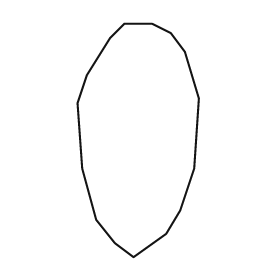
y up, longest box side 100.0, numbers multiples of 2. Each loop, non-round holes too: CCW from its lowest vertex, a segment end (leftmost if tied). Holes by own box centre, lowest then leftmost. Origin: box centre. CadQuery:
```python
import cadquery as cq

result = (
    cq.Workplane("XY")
    .moveTo(-2.0, -50.0)
    .lineTo(12.0, -40.0)
    .lineTo(18.0, -30.0)
    .lineTo(24.0, -12.0)
    .lineTo(26.0, 18.0)
    .lineTo(20.0, 38.0)
    .lineTo(14.0, 46.0)
    .lineTo(6.0, 50.0)
    .lineTo(-6.0, 50.0)
    .lineTo(-12.0, 44.0)
    .lineTo(-22.0, 28.0)
    .lineTo(-26.0, 16.0)
    .lineTo(-24.0, -12.0)
    .lineTo(-18.0, -34.0)
    .lineTo(-10.0, -44.0)
    .close()
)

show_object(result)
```